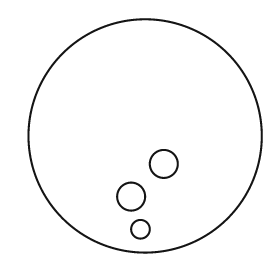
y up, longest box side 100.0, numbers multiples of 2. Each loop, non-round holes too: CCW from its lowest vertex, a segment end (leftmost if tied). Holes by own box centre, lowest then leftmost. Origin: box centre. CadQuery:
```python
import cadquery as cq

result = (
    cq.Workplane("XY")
    .moveTo(0.0, 0.0)
    .circle(50.0)
    .moveTo(-2.0, -40.0)
    .circle(4.0)
    .moveTo(-6.0, -26.0)
    .circle(6.0)
    .moveTo(8.0, -12.0)
    .circle(6.0)
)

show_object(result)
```